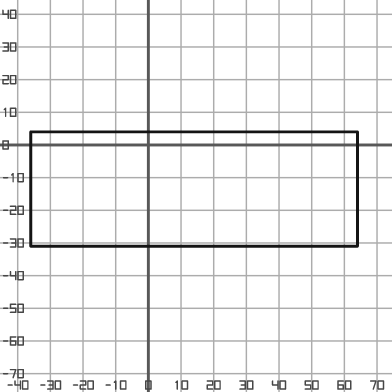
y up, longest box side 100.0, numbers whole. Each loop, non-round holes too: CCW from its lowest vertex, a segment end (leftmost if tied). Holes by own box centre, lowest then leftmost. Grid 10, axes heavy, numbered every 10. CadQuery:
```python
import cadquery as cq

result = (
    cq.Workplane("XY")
    .moveTo(-36.0, -31.0)
    .lineTo(64.0, -31.0)
    .lineTo(64.0, 4.0)
    .lineTo(-36.0, 4.0)
    .close()
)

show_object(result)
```